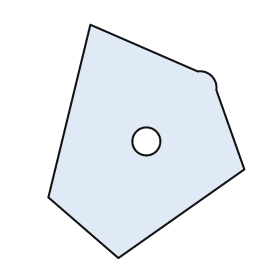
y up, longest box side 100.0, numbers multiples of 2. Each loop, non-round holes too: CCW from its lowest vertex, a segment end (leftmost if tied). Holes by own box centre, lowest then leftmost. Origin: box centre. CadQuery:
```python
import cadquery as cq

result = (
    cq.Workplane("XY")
    .moveTo(-12.0, -50.0)
    .lineTo(42.0, -12.0)
    .lineTo(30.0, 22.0)
    .threePointArc((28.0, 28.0), (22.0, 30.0))
    .lineTo(-24.0, 50.0)
    .lineTo(-42.0, -24.0)
    .close()
    .moveTo(0.0, 0.0)
    .circle(6.0)
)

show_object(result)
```